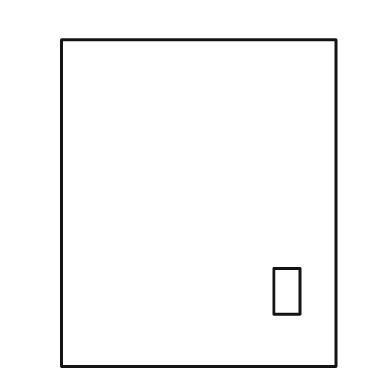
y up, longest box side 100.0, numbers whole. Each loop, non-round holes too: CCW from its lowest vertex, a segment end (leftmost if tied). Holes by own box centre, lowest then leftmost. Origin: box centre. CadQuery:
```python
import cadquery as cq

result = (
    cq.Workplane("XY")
    .moveTo(-42.0, -50.0)
    .lineTo(42.0, -50.0)
    .lineTo(42.0, 50.0)
    .lineTo(-42.0, 50.0)
    .close()
    .moveTo(23.0, -34.0)
    .lineTo(31.0, -34.0)
    .lineTo(31.0, -20.0)
    .lineTo(23.0, -20.0)
    .close()
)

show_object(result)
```